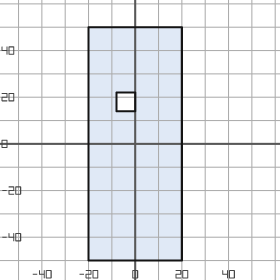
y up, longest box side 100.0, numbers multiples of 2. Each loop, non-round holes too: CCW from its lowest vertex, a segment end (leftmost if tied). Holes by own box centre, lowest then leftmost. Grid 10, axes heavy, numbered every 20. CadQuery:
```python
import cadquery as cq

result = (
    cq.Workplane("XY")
    .moveTo(-20.0, -50.0)
    .lineTo(20.0, -50.0)
    .lineTo(20.0, 50.0)
    .lineTo(-20.0, 50.0)
    .close()
    .moveTo(-8.0, 14.0)
    .lineTo(0.0, 14.0)
    .lineTo(0.0, 22.0)
    .lineTo(-8.0, 22.0)
    .close()
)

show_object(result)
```